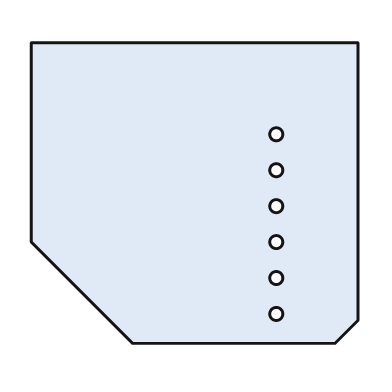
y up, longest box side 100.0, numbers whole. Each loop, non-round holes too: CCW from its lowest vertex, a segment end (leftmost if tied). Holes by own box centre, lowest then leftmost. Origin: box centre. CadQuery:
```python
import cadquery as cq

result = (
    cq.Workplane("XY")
    .moveTo(-19.0, -46.0)
    .lineTo(43.0, -46.0)
    .lineTo(50.0, -39.0)
    .lineTo(50.0, 46.0)
    .lineTo(-50.0, 46.0)
    .lineTo(-50.0, -15.0)
    .close()
    .moveTo(25.0, -37.0)
    .circle(2.0)
    .moveTo(25.0, -26.0)
    .circle(2.0)
    .moveTo(25.0, -15.0)
    .circle(2.0)
    .moveTo(25.0, -4.0)
    .circle(2.0)
    .moveTo(25.0, 7.0)
    .circle(2.0)
    .moveTo(25.0, 18.0)
    .circle(2.0)
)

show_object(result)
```